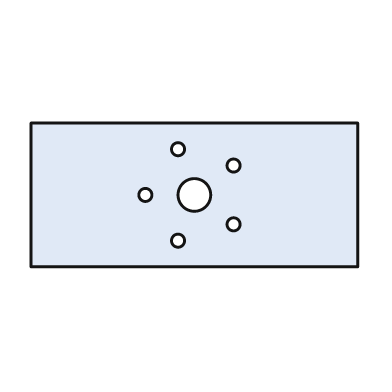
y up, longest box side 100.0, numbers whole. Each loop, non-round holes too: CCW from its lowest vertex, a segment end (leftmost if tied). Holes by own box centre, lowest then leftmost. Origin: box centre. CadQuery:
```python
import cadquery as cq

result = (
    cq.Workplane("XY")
    .moveTo(-50.0, -22.0)
    .lineTo(50.0, -22.0)
    .lineTo(50.0, 22.0)
    .lineTo(-50.0, 22.0)
    .close()
    .moveTo(-5.0, -14.0)
    .circle(2.0)
    .moveTo(12.0, -9.0)
    .circle(2.0)
    .moveTo(-15.0, 0.0)
    .circle(2.0)
    .moveTo(0.0, 0.0)
    .circle(5.0)
    .moveTo(12.0, 9.0)
    .circle(2.0)
    .moveTo(-5.0, 14.0)
    .circle(2.0)
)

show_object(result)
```